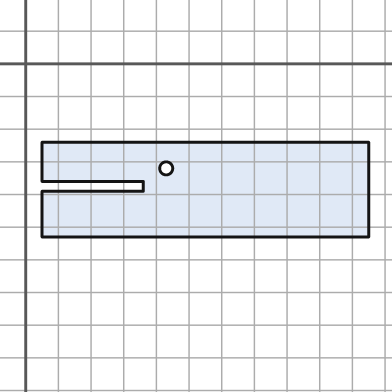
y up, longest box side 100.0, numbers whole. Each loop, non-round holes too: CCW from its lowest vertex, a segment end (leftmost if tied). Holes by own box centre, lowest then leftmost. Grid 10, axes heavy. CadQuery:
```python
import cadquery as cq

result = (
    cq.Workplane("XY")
    .moveTo(5.0, -53.0)
    .lineTo(105.0, -53.0)
    .lineTo(105.0, -24.0)
    .lineTo(5.0, -24.0)
    .lineTo(5.0, -36.0)
    .lineTo(36.0, -36.0)
    .lineTo(36.0, -39.0)
    .lineTo(5.0, -39.0)
    .close()
    .moveTo(43.0, -32.0)
    .circle(2.0)
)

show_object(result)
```